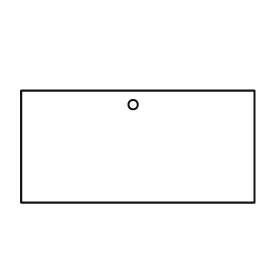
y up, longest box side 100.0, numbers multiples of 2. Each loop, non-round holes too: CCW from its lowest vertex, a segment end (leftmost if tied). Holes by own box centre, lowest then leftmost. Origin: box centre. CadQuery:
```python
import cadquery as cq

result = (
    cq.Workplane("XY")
    .moveTo(-50.0, -24.0)
    .lineTo(50.0, -24.0)
    .lineTo(50.0, 24.0)
    .lineTo(-50.0, 24.0)
    .close()
    .moveTo(-2.0, 18.0)
    .circle(2.0)
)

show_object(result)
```